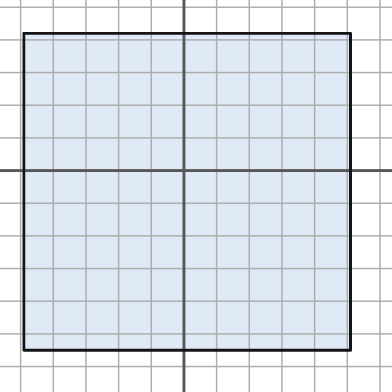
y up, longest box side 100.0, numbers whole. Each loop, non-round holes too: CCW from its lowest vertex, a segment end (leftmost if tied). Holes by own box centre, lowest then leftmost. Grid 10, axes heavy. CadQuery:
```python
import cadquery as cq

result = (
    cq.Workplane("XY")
    .moveTo(-49.0, -55.0)
    .lineTo(51.0, -55.0)
    .lineTo(51.0, 42.0)
    .lineTo(-49.0, 42.0)
    .close()
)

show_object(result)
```